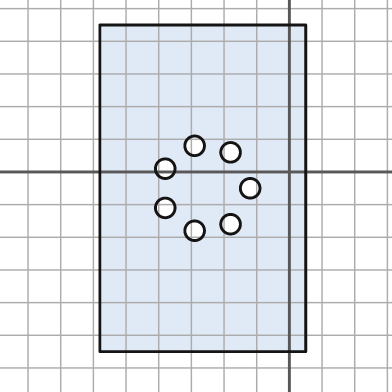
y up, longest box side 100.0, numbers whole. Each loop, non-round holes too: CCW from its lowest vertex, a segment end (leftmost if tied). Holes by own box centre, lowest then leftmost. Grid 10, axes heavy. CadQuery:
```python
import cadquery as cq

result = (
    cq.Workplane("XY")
    .moveTo(-58.0, -55.0)
    .lineTo(5.0, -55.0)
    .lineTo(5.0, 45.0)
    .lineTo(-58.0, 45.0)
    .close()
    .moveTo(-29.0, -18.0)
    .circle(3.0)
    .moveTo(-18.0, -16.0)
    .circle(3.0)
    .moveTo(-38.0, -11.0)
    .circle(3.0)
    .moveTo(-12.0, -5.0)
    .circle(3.0)
    .moveTo(-38.0, 1.0)
    .circle(3.0)
    .moveTo(-18.0, 6.0)
    .circle(3.0)
    .moveTo(-29.0, 8.0)
    .circle(3.0)
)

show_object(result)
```